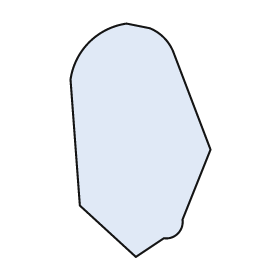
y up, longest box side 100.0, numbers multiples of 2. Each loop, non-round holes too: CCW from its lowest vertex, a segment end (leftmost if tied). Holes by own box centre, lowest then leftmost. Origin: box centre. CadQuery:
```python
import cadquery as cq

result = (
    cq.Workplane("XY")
    .moveTo(-2.0, -50.0)
    .lineTo(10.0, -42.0)
    .threePointArc((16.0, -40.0), (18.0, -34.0))
    .lineTo(30.0, -4.0)
    .lineTo(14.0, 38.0)
    .threePointArc((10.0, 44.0), (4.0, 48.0))
    .lineTo(-6.0, 50.0)
    .threePointArc((-22.0, 42.0), (-30.0, 26.0))
    .lineTo(-26.0, -28.0)
    .close()
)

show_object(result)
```